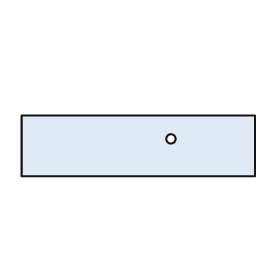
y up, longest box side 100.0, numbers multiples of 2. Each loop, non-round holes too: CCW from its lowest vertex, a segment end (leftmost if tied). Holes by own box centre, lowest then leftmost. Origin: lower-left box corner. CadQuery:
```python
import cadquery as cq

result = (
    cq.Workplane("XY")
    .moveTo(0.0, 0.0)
    .lineTo(100.0, 0.0)
    .lineTo(100.0, 26.0)
    .lineTo(0.0, 26.0)
    .close()
    .moveTo(64.0, 16.0)
    .circle(2.0)
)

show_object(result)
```